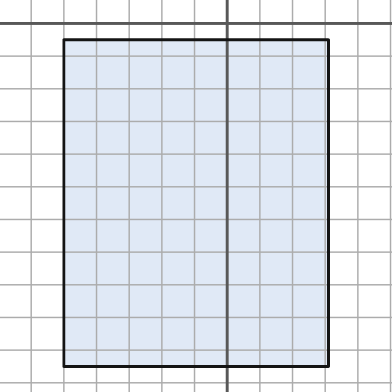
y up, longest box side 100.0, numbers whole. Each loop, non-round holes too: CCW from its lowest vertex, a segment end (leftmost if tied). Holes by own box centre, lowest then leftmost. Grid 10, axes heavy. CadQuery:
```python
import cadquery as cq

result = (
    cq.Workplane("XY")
    .moveTo(-50.0, -105.0)
    .lineTo(31.0, -105.0)
    .lineTo(31.0, -5.0)
    .lineTo(-50.0, -5.0)
    .close()
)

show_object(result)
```